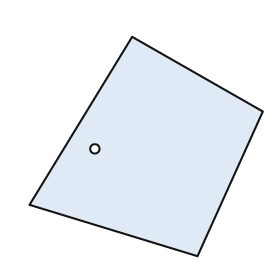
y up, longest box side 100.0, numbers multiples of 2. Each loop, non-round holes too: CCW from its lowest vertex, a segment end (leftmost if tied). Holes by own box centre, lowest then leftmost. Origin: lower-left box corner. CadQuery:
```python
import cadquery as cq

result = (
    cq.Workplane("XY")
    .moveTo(72.0, 0.0)
    .lineTo(100.0, 62.0)
    .lineTo(44.0, 94.0)
    .lineTo(0.0, 22.0)
    .close()
    .moveTo(28.0, 46.0)
    .circle(2.0)
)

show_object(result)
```